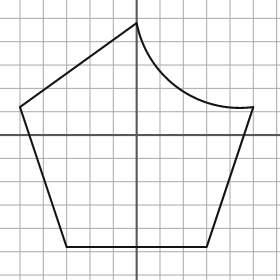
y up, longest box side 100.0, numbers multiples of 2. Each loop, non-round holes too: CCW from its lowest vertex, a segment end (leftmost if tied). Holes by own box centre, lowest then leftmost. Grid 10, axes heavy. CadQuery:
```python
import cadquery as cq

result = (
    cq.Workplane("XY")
    .moveTo(-30.0, -48.0)
    .lineTo(30.0, -48.0)
    .lineTo(50.0, 12.0)
    .threePointArc((18.0, 20.0), (0.0, 48.0))
    .lineTo(-50.0, 12.0)
    .close()
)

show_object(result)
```